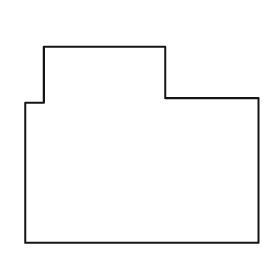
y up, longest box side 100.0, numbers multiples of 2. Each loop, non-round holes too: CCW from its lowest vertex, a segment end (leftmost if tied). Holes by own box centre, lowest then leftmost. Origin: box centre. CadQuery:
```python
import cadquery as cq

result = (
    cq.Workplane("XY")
    .moveTo(-50.0, -42.0)
    .lineTo(50.0, -42.0)
    .lineTo(50.0, 20.0)
    .lineTo(10.0, 20.0)
    .lineTo(10.0, 42.0)
    .lineTo(-42.0, 42.0)
    .lineTo(-42.0, 18.0)
    .lineTo(-50.0, 18.0)
    .close()
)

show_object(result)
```